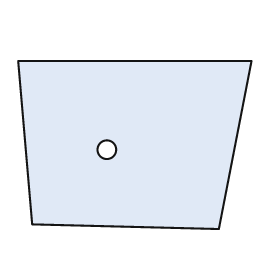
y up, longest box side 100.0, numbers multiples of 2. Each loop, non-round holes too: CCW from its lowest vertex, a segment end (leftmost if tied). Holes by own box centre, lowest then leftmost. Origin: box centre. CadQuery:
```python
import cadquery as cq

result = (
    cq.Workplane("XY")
    .moveTo(36.0, -36.0)
    .lineTo(50.0, 36.0)
    .lineTo(-50.0, 36.0)
    .lineTo(-44.0, -34.0)
    .close()
    .moveTo(-12.0, -2.0)
    .circle(4.0)
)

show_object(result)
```